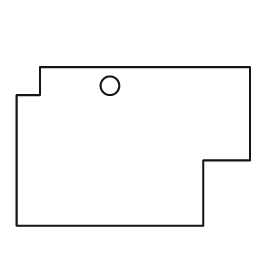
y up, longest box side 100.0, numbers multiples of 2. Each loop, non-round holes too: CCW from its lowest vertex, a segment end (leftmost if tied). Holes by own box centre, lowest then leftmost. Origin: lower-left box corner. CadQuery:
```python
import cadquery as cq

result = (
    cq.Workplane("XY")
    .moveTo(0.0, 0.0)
    .lineTo(80.0, 0.0)
    .lineTo(80.0, 28.0)
    .lineTo(100.0, 28.0)
    .lineTo(100.0, 68.0)
    .lineTo(10.0, 68.0)
    .lineTo(10.0, 56.0)
    .lineTo(0.0, 56.0)
    .close()
    .moveTo(40.0, 60.0)
    .circle(4.0)
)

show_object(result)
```